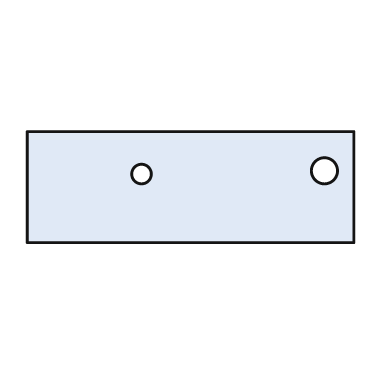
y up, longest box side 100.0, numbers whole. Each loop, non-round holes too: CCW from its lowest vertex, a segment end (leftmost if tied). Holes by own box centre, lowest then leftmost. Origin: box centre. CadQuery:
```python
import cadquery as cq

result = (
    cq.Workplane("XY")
    .moveTo(-50.0, -17.0)
    .lineTo(50.0, -17.0)
    .lineTo(50.0, 17.0)
    .lineTo(-50.0, 17.0)
    .close()
    .moveTo(-15.0, 4.0)
    .circle(3.0)
    .moveTo(41.0, 5.0)
    .circle(4.0)
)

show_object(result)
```